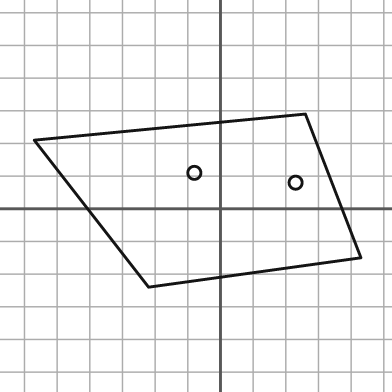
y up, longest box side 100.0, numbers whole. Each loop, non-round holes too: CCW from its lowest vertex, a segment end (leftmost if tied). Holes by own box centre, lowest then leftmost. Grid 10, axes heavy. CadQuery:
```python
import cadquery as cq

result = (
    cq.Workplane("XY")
    .moveTo(-22.0, -24.0)
    .lineTo(43.0, -15.0)
    .lineTo(26.0, 29.0)
    .lineTo(-57.0, 21.0)
    .close()
    .moveTo(23.0, 8.0)
    .circle(2.0)
    .moveTo(-8.0, 11.0)
    .circle(2.0)
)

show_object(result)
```